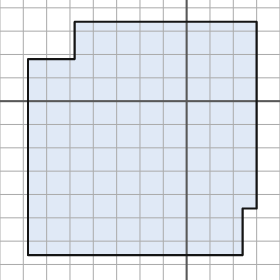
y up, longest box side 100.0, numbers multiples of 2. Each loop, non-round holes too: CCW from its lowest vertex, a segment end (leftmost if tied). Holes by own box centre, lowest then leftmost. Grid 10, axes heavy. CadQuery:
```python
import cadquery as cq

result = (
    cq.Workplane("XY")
    .moveTo(-68.0, -66.0)
    .lineTo(24.0, -66.0)
    .lineTo(24.0, -46.0)
    .lineTo(30.0, -46.0)
    .lineTo(30.0, 34.0)
    .lineTo(-48.0, 34.0)
    .lineTo(-48.0, 18.0)
    .lineTo(-68.0, 18.0)
    .close()
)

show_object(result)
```